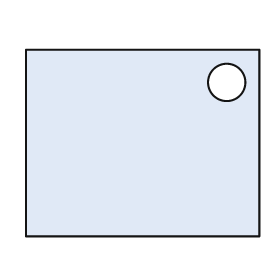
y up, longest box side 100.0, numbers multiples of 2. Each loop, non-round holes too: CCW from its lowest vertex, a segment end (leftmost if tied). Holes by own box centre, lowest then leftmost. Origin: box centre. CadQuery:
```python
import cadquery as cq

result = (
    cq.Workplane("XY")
    .moveTo(-50.0, -40.0)
    .lineTo(50.0, -40.0)
    .lineTo(50.0, 40.0)
    .lineTo(-50.0, 40.0)
    .close()
    .moveTo(36.0, 26.0)
    .circle(8.0)
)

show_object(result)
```